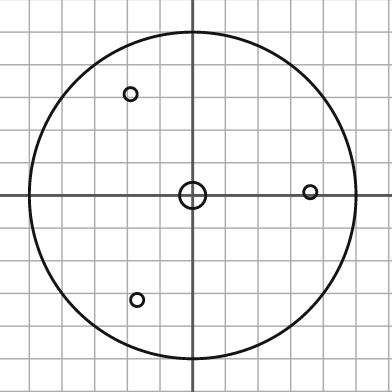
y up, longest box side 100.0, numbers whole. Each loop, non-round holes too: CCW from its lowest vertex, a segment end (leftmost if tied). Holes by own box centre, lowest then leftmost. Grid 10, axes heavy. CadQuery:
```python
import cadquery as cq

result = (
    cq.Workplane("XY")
    .moveTo(0.0, 0.0)
    .circle(50.0)
    .moveTo(-17.0, -32.0)
    .circle(2.0)
    .moveTo(0.0, 0.0)
    .circle(4.0)
    .moveTo(36.0, 1.0)
    .circle(2.0)
    .moveTo(-19.0, 31.0)
    .circle(2.0)
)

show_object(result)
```